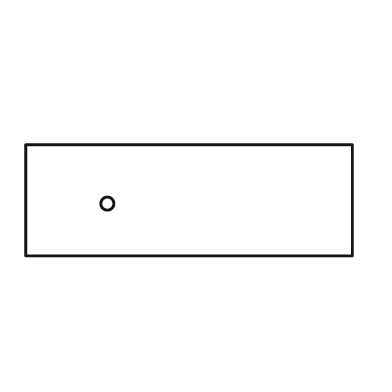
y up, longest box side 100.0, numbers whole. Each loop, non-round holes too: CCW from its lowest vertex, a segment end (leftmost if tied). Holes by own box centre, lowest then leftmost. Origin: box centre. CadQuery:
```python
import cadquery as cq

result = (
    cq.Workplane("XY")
    .moveTo(-50.0, -17.0)
    .lineTo(50.0, -17.0)
    .lineTo(50.0, 17.0)
    .lineTo(-50.0, 17.0)
    .close()
    .moveTo(-25.0, -1.0)
    .circle(2.0)
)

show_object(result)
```